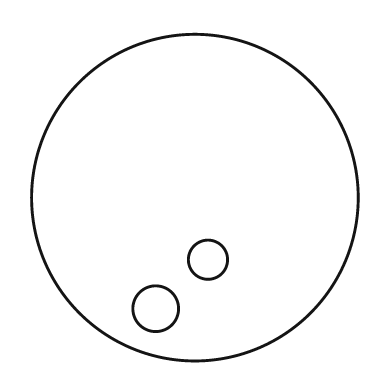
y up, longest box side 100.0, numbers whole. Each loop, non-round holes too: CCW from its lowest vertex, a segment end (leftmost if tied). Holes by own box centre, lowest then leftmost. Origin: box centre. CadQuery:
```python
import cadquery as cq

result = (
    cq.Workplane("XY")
    .moveTo(0.0, 0.0)
    .circle(50.0)
    .moveTo(-12.0, -34.0)
    .circle(7.0)
    .moveTo(4.0, -19.0)
    .circle(6.0)
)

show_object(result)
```